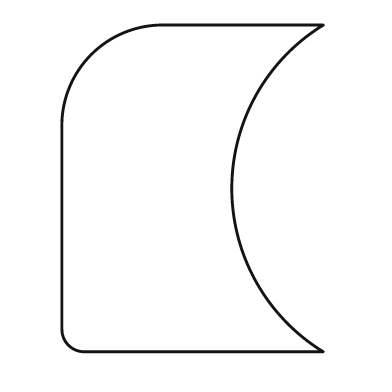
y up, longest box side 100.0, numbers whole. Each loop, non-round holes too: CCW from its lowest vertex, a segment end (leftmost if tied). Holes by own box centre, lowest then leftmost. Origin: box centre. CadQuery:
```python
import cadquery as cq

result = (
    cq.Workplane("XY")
    .moveTo(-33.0, -50.0)
    .lineTo(40.0, -50.0)
    .threePointArc((12.0, 0.0), (40.0, 50.0))
    .lineTo(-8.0, 50.0)
    .threePointArc((-31.0, 41.0), (-40.0, 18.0))
    .lineTo(-40.0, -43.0)
    .threePointArc((-38.0, -48.0), (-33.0, -50.0))
    .close()
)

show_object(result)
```